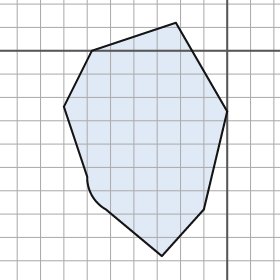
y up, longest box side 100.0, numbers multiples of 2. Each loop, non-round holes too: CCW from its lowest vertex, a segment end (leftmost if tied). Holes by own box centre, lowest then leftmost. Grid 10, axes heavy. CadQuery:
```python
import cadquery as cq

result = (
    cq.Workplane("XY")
    .moveTo(-28.0, -88.0)
    .lineTo(-10.0, -68.0)
    .lineTo(0.0, -26.0)
    .lineTo(-22.0, 12.0)
    .lineTo(-58.0, 0.0)
    .lineTo(-70.0, -24.0)
    .lineTo(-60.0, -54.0)
    .threePointArc((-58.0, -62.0), (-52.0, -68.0))
    .close()
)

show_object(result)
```